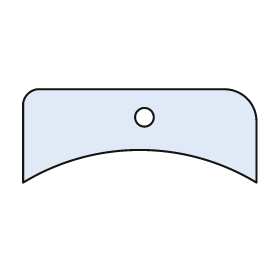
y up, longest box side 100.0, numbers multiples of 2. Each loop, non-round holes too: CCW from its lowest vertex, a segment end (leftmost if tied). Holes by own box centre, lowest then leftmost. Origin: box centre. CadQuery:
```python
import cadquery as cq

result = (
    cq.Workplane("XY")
    .moveTo(-50.0, -20.0)
    .threePointArc((0.0, -6.0), (50.0, -20.0))
    .lineTo(50.0, 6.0)
    .threePointArc((46.0, 16.0), (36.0, 20.0))
    .lineTo(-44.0, 20.0)
    .threePointArc((-48.0, 18.0), (-50.0, 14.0))
    .close()
    .moveTo(2.0, 8.0)
    .circle(4.0)
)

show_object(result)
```